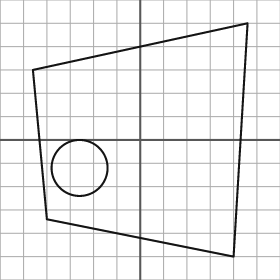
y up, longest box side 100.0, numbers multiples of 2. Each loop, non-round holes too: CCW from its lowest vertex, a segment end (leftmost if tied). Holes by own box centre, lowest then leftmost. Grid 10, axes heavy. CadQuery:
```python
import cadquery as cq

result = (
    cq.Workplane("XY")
    .moveTo(40.0, -50.0)
    .lineTo(46.0, 50.0)
    .lineTo(-46.0, 30.0)
    .lineTo(-40.0, -34.0)
    .close()
    .moveTo(-26.0, -12.0)
    .circle(12.0)
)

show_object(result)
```